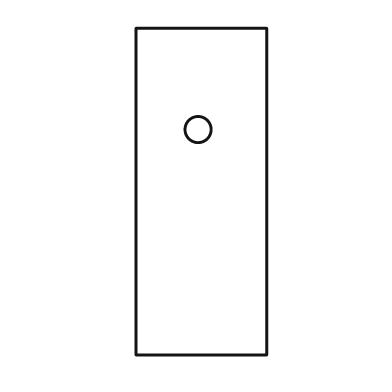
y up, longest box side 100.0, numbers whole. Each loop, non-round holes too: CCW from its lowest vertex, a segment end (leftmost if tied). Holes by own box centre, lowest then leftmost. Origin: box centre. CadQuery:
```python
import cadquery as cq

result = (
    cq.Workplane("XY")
    .moveTo(-20.0, -50.0)
    .lineTo(20.0, -50.0)
    .lineTo(20.0, 50.0)
    .lineTo(-20.0, 50.0)
    .close()
    .moveTo(-1.0, 19.0)
    .circle(4.0)
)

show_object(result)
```